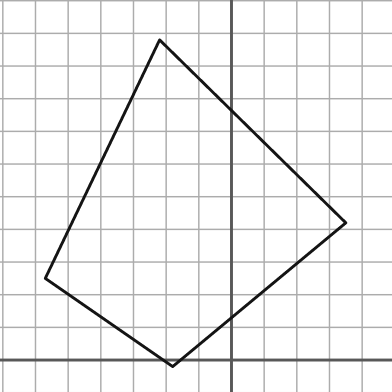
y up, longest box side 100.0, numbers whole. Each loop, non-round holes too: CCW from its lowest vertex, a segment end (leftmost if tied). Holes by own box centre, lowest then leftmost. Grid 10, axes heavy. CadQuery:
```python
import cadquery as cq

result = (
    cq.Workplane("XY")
    .moveTo(-18.0, -2.0)
    .lineTo(35.0, 42.0)
    .lineTo(-22.0, 98.0)
    .lineTo(-57.0, 25.0)
    .close()
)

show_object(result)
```